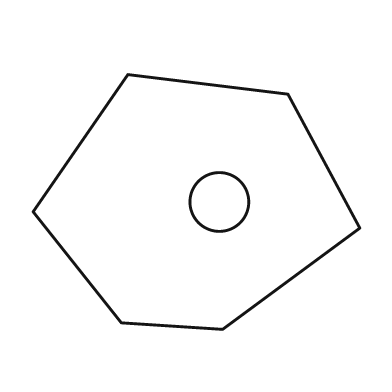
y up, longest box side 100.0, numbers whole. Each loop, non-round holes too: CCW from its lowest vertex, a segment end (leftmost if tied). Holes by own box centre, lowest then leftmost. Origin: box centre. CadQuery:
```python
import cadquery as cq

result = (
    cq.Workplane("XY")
    .moveTo(8.0, -39.0)
    .lineTo(50.0, -8.0)
    .lineTo(28.0, 33.0)
    .lineTo(-21.0, 39.0)
    .lineTo(-50.0, -3.0)
    .lineTo(-23.0, -37.0)
    .close()
    .moveTo(7.0, 0.0)
    .circle(9.0)
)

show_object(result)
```